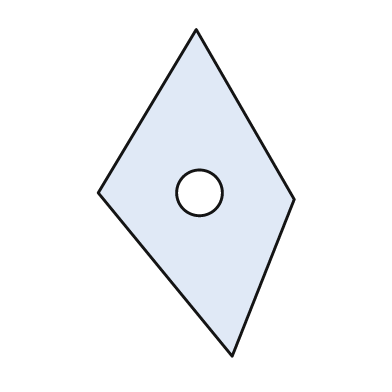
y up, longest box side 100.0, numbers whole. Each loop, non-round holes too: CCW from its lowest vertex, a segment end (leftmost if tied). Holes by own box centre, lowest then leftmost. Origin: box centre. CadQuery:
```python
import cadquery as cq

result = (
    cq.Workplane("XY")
    .moveTo(11.0, -50.0)
    .lineTo(30.0, -2.0)
    .lineTo(0.0, 50.0)
    .lineTo(-30.0, 0.0)
    .close()
    .moveTo(1.0, 0.0)
    .circle(7.0)
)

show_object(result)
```